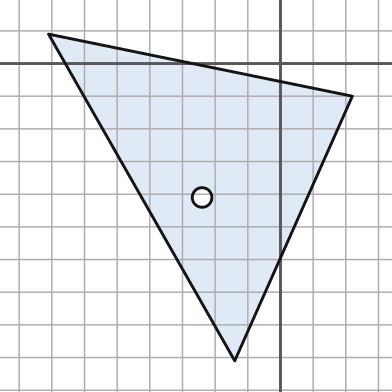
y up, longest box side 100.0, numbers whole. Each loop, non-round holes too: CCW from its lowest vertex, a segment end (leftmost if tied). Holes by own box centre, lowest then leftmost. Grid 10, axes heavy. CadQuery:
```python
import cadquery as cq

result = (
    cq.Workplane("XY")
    .moveTo(-14.0, -91.0)
    .lineTo(22.0, -10.0)
    .lineTo(-71.0, 9.0)
    .close()
    .moveTo(-24.0, -41.0)
    .circle(3.0)
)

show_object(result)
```